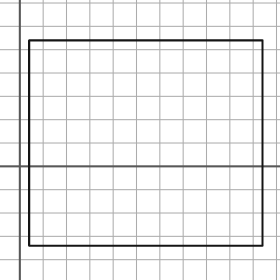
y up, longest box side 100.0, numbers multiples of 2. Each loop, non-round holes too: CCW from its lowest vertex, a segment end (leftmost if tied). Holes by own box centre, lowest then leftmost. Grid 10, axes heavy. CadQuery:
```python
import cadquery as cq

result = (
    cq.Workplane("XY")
    .moveTo(4.0, -34.0)
    .lineTo(104.0, -34.0)
    .lineTo(104.0, 54.0)
    .lineTo(4.0, 54.0)
    .close()
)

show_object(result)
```